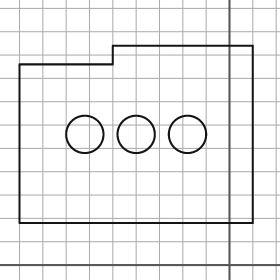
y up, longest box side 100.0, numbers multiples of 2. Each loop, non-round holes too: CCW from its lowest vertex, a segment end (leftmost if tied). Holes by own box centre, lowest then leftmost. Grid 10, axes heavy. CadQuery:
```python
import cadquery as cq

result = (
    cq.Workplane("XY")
    .moveTo(-90.0, 18.0)
    .lineTo(10.0, 18.0)
    .lineTo(10.0, 94.0)
    .lineTo(-50.0, 94.0)
    .lineTo(-50.0, 86.0)
    .lineTo(-90.0, 86.0)
    .close()
    .moveTo(-62.0, 56.0)
    .circle(8.0)
    .moveTo(-40.0, 56.0)
    .circle(8.0)
    .moveTo(-18.0, 56.0)
    .circle(8.0)
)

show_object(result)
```